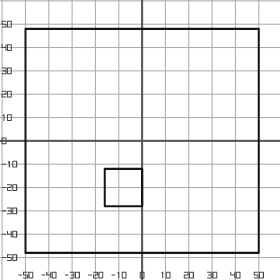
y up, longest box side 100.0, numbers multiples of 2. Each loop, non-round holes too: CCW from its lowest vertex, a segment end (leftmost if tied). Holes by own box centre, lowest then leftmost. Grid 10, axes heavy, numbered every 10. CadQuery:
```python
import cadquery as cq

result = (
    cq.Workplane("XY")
    .moveTo(-50.0, -48.0)
    .lineTo(50.0, -48.0)
    .lineTo(50.0, 48.0)
    .lineTo(-50.0, 48.0)
    .close()
    .moveTo(-16.0, -28.0)
    .lineTo(0.0, -28.0)
    .lineTo(0.0, -12.0)
    .lineTo(-16.0, -12.0)
    .close()
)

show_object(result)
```